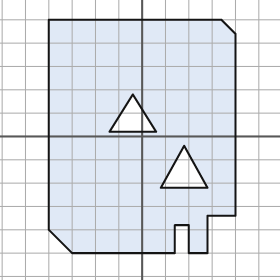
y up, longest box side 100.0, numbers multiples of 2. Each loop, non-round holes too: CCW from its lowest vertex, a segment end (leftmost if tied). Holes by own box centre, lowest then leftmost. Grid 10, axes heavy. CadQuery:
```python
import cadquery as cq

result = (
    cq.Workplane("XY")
    .moveTo(-30.0, -50.0)
    .lineTo(14.0, -50.0)
    .lineTo(14.0, -38.0)
    .lineTo(20.0, -38.0)
    .lineTo(20.0, -50.0)
    .lineTo(28.0, -50.0)
    .lineTo(28.0, -34.0)
    .lineTo(40.0, -34.0)
    .lineTo(40.0, 44.0)
    .lineTo(34.0, 50.0)
    .lineTo(-40.0, 50.0)
    .lineTo(-40.0, -40.0)
    .close()
    .moveTo(8.0, -22.0)
    .lineTo(28.0, -22.0)
    .lineTo(18.0, -4.0)
    .close()
    .moveTo(-14.0, 2.0)
    .lineTo(6.0, 2.0)
    .lineTo(-4.0, 18.0)
    .close()
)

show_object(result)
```